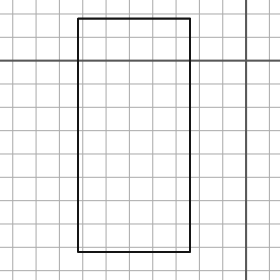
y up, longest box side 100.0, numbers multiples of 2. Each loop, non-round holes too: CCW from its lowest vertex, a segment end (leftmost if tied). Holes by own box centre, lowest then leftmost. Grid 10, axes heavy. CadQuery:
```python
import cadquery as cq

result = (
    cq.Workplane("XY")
    .moveTo(-72.0, -82.0)
    .lineTo(-24.0, -82.0)
    .lineTo(-24.0, 18.0)
    .lineTo(-72.0, 18.0)
    .close()
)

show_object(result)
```